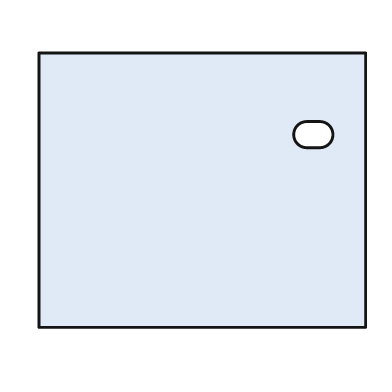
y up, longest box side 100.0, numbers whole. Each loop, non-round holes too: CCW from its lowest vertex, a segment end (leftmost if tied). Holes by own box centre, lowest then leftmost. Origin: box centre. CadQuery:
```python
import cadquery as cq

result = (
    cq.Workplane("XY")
    .moveTo(-50.0, -42.0)
    .lineTo(50.0, -42.0)
    .lineTo(50.0, 42.0)
    .lineTo(-50.0, 42.0)
    .close()
    .moveTo(32.0, 13.0)
    .lineTo(36.0, 13.0)
    .threePointArc((40.0, 17.0), (36.0, 21.0))
    .lineTo(32.0, 21.0)
    .threePointArc((28.0, 17.0), (32.0, 13.0))
    .close()
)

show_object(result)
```